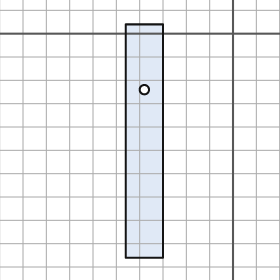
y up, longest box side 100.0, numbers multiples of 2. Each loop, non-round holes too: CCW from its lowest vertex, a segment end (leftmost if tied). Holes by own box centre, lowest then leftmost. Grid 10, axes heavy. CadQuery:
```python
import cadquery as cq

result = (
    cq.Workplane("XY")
    .moveTo(-46.0, -96.0)
    .lineTo(-30.0, -96.0)
    .lineTo(-30.0, 4.0)
    .lineTo(-46.0, 4.0)
    .close()
    .moveTo(-38.0, -24.0)
    .circle(2.0)
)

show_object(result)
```